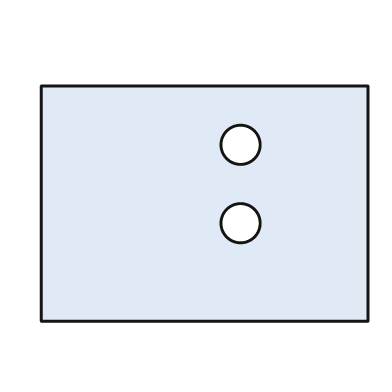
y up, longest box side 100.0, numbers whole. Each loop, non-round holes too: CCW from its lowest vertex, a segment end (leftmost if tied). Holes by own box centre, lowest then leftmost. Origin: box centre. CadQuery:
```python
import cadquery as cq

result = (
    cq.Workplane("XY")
    .moveTo(-50.0, -36.0)
    .lineTo(50.0, -36.0)
    .lineTo(50.0, 36.0)
    .lineTo(-50.0, 36.0)
    .close()
    .moveTo(11.0, -6.0)
    .circle(6.0)
    .moveTo(11.0, 18.0)
    .circle(6.0)
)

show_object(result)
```